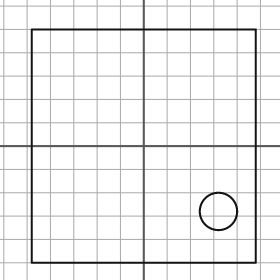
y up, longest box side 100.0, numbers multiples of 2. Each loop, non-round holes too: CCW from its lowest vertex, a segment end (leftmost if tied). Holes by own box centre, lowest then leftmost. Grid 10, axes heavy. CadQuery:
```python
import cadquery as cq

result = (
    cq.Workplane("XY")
    .moveTo(-48.0, -50.0)
    .lineTo(48.0, -50.0)
    .lineTo(48.0, 50.0)
    .lineTo(-48.0, 50.0)
    .close()
    .moveTo(32.0, -28.0)
    .circle(8.0)
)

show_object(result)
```